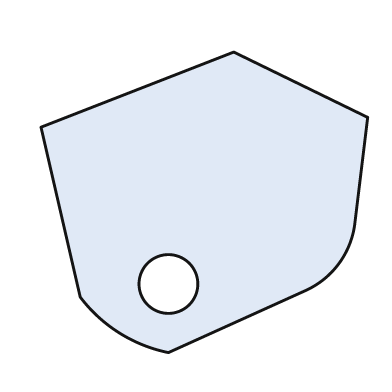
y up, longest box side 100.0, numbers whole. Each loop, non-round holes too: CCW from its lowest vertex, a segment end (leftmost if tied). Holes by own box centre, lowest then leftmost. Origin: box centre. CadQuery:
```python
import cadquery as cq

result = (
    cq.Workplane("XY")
    .moveTo(-11.0, -46.0)
    .lineTo(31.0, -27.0)
    .threePointArc((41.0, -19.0), (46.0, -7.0))
    .lineTo(50.0, 26.0)
    .lineTo(9.0, 46.0)
    .lineTo(-50.0, 23.0)
    .lineTo(-38.0, -29.0)
    .threePointArc((-26.0, -40.0), (-11.0, -46.0))
    .close()
    .moveTo(-11.0, -25.0)
    .circle(9.0)
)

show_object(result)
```